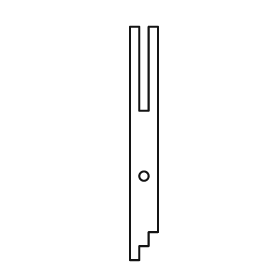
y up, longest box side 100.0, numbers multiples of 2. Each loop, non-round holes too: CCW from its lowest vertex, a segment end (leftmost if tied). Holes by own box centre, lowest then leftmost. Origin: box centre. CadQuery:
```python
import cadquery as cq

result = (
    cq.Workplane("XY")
    .moveTo(-6.0, -50.0)
    .lineTo(-2.0, -50.0)
    .lineTo(-2.0, -44.0)
    .lineTo(2.0, -44.0)
    .lineTo(2.0, -38.0)
    .lineTo(6.0, -38.0)
    .lineTo(6.0, 50.0)
    .lineTo(2.0, 50.0)
    .lineTo(2.0, 14.0)
    .lineTo(-2.0, 14.0)
    .lineTo(-2.0, 50.0)
    .lineTo(-6.0, 50.0)
    .close()
    .moveTo(0.0, -14.0)
    .circle(2.0)
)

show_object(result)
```